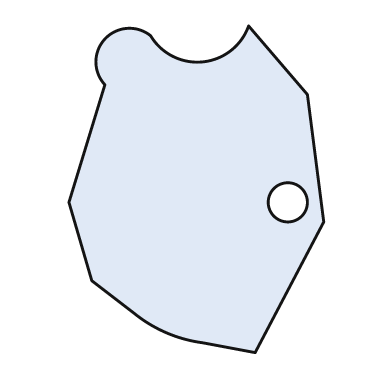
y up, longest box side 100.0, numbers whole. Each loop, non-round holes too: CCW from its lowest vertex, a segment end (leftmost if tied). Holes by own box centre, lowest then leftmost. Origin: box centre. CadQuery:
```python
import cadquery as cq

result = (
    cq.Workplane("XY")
    .moveTo(18.0, -50.0)
    .lineTo(39.0, -10.0)
    .lineTo(34.0, 29.0)
    .lineTo(16.0, 50.0)
    .threePointArc((2.0, 39.0), (-14.0, 47.0))
    .threePointArc((-28.0, 46.0), (-28.0, 32.0))
    .lineTo(-39.0, -4.0)
    .lineTo(-32.0, -28.0)
    .lineTo(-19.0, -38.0)
    .threePointArc((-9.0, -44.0), (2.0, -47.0))
    .close()
    .moveTo(28.0, -4.0)
    .circle(6.0)
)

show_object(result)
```